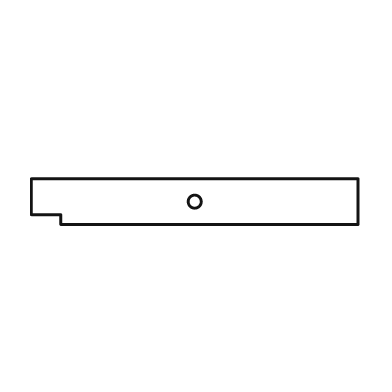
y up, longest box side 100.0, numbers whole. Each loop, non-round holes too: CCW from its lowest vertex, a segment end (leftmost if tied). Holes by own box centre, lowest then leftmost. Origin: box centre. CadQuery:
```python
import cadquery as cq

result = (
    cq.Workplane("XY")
    .moveTo(-41.0, -7.0)
    .lineTo(50.0, -7.0)
    .lineTo(50.0, 7.0)
    .lineTo(-50.0, 7.0)
    .lineTo(-50.0, -4.0)
    .lineTo(-41.0, -4.0)
    .close()
    .moveTo(0.0, 0.0)
    .circle(2.0)
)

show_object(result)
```